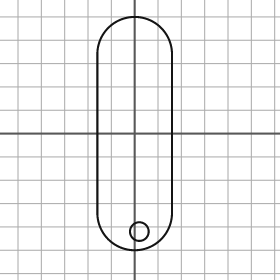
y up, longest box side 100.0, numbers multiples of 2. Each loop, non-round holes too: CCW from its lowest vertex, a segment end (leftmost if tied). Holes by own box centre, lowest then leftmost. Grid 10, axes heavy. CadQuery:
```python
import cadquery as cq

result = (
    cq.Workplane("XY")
    .moveTo(-16.0, -34.0)
    .threePointArc((0.0, -50.0), (16.0, -34.0))
    .lineTo(16.0, 34.0)
    .threePointArc((0.0, 50.0), (-16.0, 34.0))
    .close()
    .moveTo(2.0, -42.0)
    .circle(4.0)
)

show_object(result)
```